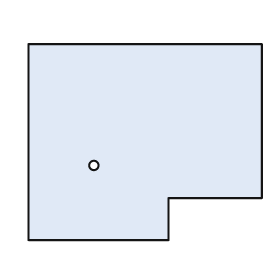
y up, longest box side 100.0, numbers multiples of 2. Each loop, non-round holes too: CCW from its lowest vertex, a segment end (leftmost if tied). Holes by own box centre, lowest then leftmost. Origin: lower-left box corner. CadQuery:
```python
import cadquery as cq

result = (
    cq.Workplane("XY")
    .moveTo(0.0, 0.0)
    .lineTo(60.0, 0.0)
    .lineTo(60.0, 18.0)
    .lineTo(100.0, 18.0)
    .lineTo(100.0, 84.0)
    .lineTo(0.0, 84.0)
    .close()
    .moveTo(28.0, 32.0)
    .circle(2.0)
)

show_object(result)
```